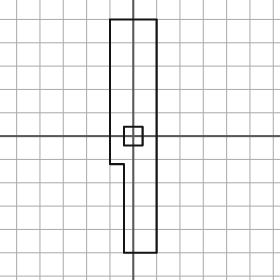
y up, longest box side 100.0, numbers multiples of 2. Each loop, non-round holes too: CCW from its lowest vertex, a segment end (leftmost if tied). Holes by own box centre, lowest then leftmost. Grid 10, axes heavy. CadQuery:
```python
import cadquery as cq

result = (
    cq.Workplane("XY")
    .moveTo(-4.0, -50.0)
    .lineTo(10.0, -50.0)
    .lineTo(10.0, 50.0)
    .lineTo(-10.0, 50.0)
    .lineTo(-10.0, -12.0)
    .lineTo(-4.0, -12.0)
    .close()
    .moveTo(-4.0, -4.0)
    .lineTo(4.0, -4.0)
    .lineTo(4.0, 4.0)
    .lineTo(-4.0, 4.0)
    .close()
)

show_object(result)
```